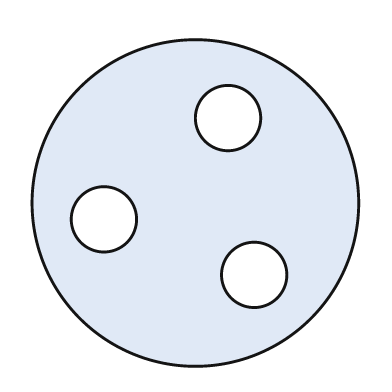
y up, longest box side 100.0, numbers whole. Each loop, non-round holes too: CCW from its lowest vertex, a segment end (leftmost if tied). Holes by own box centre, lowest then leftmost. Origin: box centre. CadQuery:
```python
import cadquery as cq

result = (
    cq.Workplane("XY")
    .moveTo(0.0, 0.0)
    .circle(50.0)
    .moveTo(18.0, -22.0)
    .circle(10.0)
    .moveTo(-28.0, -5.0)
    .circle(10.0)
    .moveTo(10.0, 26.0)
    .circle(10.0)
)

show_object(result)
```